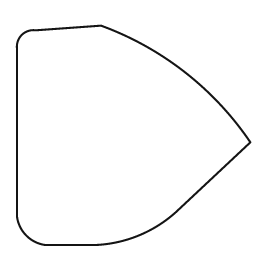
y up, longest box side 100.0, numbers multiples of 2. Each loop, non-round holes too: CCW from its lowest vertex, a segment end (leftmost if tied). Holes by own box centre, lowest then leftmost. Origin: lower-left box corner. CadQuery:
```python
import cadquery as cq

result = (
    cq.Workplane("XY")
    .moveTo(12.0, 0.0)
    .lineTo(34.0, 0.0)
    .threePointArc((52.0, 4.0), (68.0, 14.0))
    .lineTo(100.0, 44.0)
    .threePointArc((72.0, 74.0), (36.0, 94.0))
    .lineTo(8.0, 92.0)
    .threePointArc((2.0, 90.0), (0.0, 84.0))
    .lineTo(0.0, 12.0)
    .threePointArc((4.0, 4.0), (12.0, 0.0))
    .close()
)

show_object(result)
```